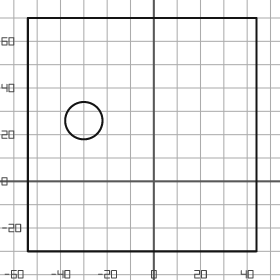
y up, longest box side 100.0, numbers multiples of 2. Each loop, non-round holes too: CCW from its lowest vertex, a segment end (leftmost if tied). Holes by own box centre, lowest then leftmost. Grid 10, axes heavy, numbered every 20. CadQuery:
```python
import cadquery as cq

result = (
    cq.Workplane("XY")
    .moveTo(-54.0, -30.0)
    .lineTo(44.0, -30.0)
    .lineTo(44.0, 70.0)
    .lineTo(-54.0, 70.0)
    .close()
    .moveTo(-30.0, 26.0)
    .circle(8.0)
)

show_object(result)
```